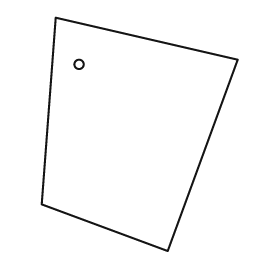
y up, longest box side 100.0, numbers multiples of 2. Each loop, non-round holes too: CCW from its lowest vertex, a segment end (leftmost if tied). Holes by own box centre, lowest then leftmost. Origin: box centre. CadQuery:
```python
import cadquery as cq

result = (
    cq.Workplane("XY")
    .moveTo(12.0, -50.0)
    .lineTo(42.0, 32.0)
    .lineTo(-36.0, 50.0)
    .lineTo(-42.0, -30.0)
    .close()
    .moveTo(-26.0, 30.0)
    .circle(2.0)
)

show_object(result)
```